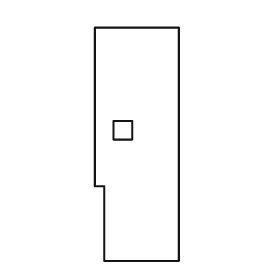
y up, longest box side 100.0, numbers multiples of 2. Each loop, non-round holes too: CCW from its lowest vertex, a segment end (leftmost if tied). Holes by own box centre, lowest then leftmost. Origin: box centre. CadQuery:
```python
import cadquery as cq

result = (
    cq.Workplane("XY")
    .moveTo(-14.0, -50.0)
    .lineTo(18.0, -50.0)
    .lineTo(18.0, 50.0)
    .lineTo(-18.0, 50.0)
    .lineTo(-18.0, -18.0)
    .lineTo(-14.0, -18.0)
    .close()
    .moveTo(-10.0, 2.0)
    .lineTo(-2.0, 2.0)
    .lineTo(-2.0, 10.0)
    .lineTo(-10.0, 10.0)
    .close()
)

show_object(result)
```